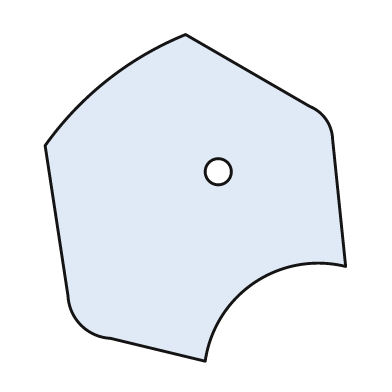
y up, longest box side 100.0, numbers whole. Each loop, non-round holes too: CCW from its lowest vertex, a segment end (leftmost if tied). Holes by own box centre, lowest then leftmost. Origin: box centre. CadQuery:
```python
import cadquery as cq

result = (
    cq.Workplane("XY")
    .moveTo(3.0, -50.0)
    .threePointArc((18.0, -26.0), (46.0, -21.0))
    .lineTo(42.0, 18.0)
    .threePointArc((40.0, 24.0), (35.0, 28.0))
    .lineTo(-3.0, 50.0)
    .threePointArc((-27.0, 36.0), (-46.0, 16.0))
    .lineTo(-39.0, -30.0)
    .threePointArc((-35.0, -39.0), (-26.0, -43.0))
    .close()
    .moveTo(7.0, 8.0)
    .circle(4.0)
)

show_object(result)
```